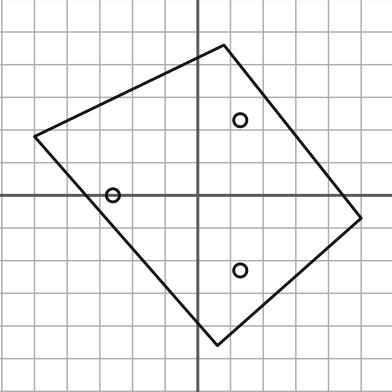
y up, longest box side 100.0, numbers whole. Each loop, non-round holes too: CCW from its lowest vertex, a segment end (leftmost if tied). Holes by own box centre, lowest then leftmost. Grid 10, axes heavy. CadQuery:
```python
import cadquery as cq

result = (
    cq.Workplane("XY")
    .moveTo(6.0, -46.0)
    .lineTo(50.0, -7.0)
    .lineTo(8.0, 46.0)
    .lineTo(-50.0, 18.0)
    .close()
    .moveTo(13.0, -23.0)
    .circle(2.0)
    .moveTo(-26.0, 0.0)
    .circle(2.0)
    .moveTo(13.0, 23.0)
    .circle(2.0)
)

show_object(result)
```